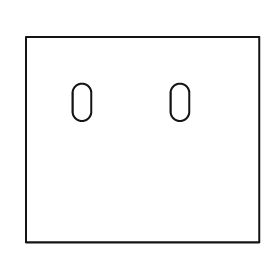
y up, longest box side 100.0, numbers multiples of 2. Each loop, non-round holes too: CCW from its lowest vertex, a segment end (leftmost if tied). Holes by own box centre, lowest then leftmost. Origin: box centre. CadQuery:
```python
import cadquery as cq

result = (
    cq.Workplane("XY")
    .moveTo(-50.0, -44.0)
    .lineTo(50.0, -44.0)
    .lineTo(50.0, 44.0)
    .lineTo(-50.0, 44.0)
    .close()
    .moveTo(-30.0, 12.0)
    .threePointArc((-26.0, 8.0), (-22.0, 12.0))
    .lineTo(-22.0, 20.0)
    .threePointArc((-26.0, 24.0), (-30.0, 20.0))
    .close()
    .moveTo(12.0, 12.0)
    .threePointArc((16.0, 8.0), (20.0, 12.0))
    .lineTo(20.0, 20.0)
    .threePointArc((16.0, 24.0), (12.0, 20.0))
    .close()
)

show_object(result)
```